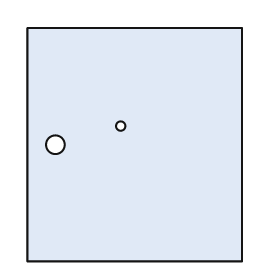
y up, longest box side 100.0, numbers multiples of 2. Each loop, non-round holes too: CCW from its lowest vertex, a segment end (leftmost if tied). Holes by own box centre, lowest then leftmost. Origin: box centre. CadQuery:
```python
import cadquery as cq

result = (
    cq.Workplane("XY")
    .moveTo(-46.0, -50.0)
    .lineTo(46.0, -50.0)
    .lineTo(46.0, 50.0)
    .lineTo(-46.0, 50.0)
    .close()
    .moveTo(-34.0, 0.0)
    .circle(4.0)
    .moveTo(-6.0, 8.0)
    .circle(2.0)
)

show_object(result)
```